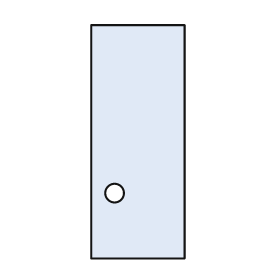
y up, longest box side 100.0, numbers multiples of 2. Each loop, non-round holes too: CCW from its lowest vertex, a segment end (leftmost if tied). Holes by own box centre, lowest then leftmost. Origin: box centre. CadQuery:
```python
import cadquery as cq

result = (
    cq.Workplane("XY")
    .moveTo(-20.0, -50.0)
    .lineTo(20.0, -50.0)
    .lineTo(20.0, 50.0)
    .lineTo(-20.0, 50.0)
    .close()
    .moveTo(-10.0, -22.0)
    .circle(4.0)
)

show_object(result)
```